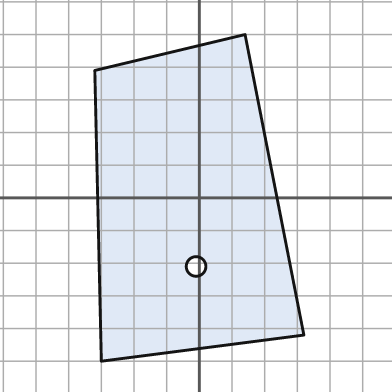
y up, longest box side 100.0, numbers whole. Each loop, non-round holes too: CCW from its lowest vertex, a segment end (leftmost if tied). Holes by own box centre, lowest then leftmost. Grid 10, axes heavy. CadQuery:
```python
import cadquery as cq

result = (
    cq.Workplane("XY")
    .moveTo(-30.0, -50.0)
    .lineTo(32.0, -42.0)
    .lineTo(14.0, 50.0)
    .lineTo(-32.0, 39.0)
    .close()
    .moveTo(-1.0, -21.0)
    .circle(3.0)
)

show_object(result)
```